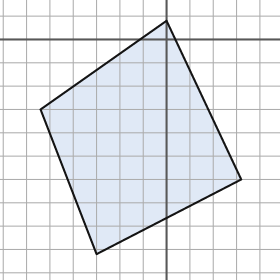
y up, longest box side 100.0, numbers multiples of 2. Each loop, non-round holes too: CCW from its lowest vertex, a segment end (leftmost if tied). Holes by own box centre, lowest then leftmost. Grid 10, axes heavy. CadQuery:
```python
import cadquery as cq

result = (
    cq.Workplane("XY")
    .moveTo(-30.0, -92.0)
    .lineTo(32.0, -60.0)
    .lineTo(0.0, 8.0)
    .lineTo(-54.0, -30.0)
    .close()
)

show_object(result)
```